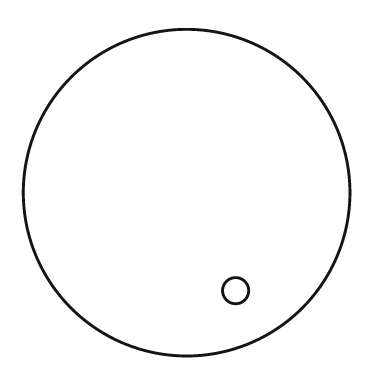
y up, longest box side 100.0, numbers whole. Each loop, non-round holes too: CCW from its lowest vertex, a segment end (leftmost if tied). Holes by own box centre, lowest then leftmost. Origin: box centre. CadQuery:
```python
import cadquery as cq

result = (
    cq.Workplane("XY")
    .moveTo(0.0, 0.0)
    .circle(50.0)
    .moveTo(15.0, -30.0)
    .circle(4.0)
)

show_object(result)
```